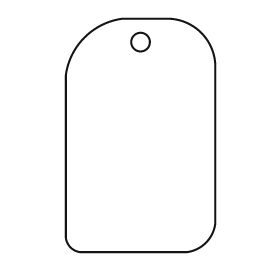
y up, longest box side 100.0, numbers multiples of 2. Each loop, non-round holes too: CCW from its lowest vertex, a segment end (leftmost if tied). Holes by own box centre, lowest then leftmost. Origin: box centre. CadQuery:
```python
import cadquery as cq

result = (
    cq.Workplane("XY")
    .moveTo(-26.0, -50.0)
    .lineTo(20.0, -50.0)
    .threePointArc((28.0, -46.0), (32.0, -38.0))
    .lineTo(32.0, 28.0)
    .threePointArc((26.0, 44.0), (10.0, 50.0))
    .lineTo(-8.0, 50.0)
    .threePointArc((-24.0, 42.0), (-32.0, 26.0))
    .lineTo(-32.0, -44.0)
    .threePointArc((-30.0, -48.0), (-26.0, -50.0))
    .close()
    .moveTo(0.0, 40.0)
    .circle(4.0)
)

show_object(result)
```